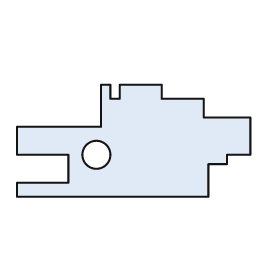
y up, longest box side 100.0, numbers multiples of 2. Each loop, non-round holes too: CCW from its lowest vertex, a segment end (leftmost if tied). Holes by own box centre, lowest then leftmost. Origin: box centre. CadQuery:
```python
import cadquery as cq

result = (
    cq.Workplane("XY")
    .moveTo(-50.0, -24.0)
    .lineTo(32.0, -24.0)
    .lineTo(32.0, -10.0)
    .lineTo(40.0, -10.0)
    .lineTo(40.0, -6.0)
    .lineTo(50.0, -6.0)
    .lineTo(50.0, 10.0)
    .lineTo(30.0, 10.0)
    .lineTo(30.0, 18.0)
    .lineTo(12.0, 18.0)
    .lineTo(12.0, 24.0)
    .lineTo(-6.0, 24.0)
    .lineTo(-6.0, 18.0)
    .lineTo(-10.0, 18.0)
    .lineTo(-10.0, 24.0)
    .lineTo(-14.0, 24.0)
    .lineTo(-14.0, 6.0)
    .lineTo(-50.0, 6.0)
    .lineTo(-50.0, -6.0)
    .lineTo(-28.0, -6.0)
    .lineTo(-28.0, -18.0)
    .lineTo(-50.0, -18.0)
    .close()
    .moveTo(-16.0, -6.0)
    .circle(6.0)
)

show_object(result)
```